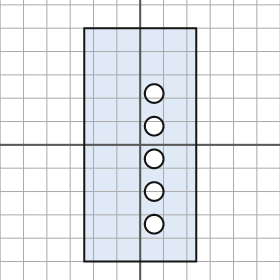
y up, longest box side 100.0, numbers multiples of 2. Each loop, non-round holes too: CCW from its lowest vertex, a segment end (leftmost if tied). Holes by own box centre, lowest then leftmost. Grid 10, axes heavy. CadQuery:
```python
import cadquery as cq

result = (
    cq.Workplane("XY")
    .moveTo(-24.0, -50.0)
    .lineTo(24.0, -50.0)
    .lineTo(24.0, 50.0)
    .lineTo(-24.0, 50.0)
    .close()
    .moveTo(6.0, -34.0)
    .circle(4.0)
    .moveTo(6.0, -20.0)
    .circle(4.0)
    .moveTo(6.0, -6.0)
    .circle(4.0)
    .moveTo(6.0, 8.0)
    .circle(4.0)
    .moveTo(6.0, 22.0)
    .circle(4.0)
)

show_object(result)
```